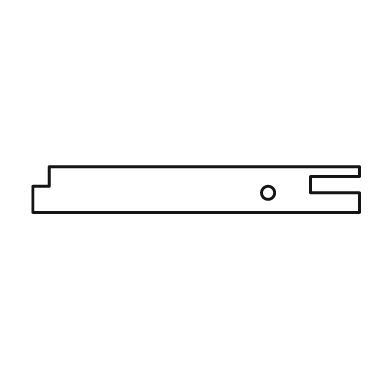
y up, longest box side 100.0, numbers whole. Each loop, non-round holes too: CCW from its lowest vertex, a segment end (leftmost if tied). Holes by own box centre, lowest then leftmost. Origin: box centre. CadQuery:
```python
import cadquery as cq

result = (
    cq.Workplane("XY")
    .moveTo(-50.0, -7.0)
    .lineTo(50.0, -7.0)
    .lineTo(50.0, -1.0)
    .lineTo(35.0, -1.0)
    .lineTo(35.0, 4.0)
    .lineTo(50.0, 4.0)
    .lineTo(50.0, 7.0)
    .lineTo(-45.0, 7.0)
    .lineTo(-45.0, 1.0)
    .lineTo(-50.0, 1.0)
    .close()
    .moveTo(22.0, -1.0)
    .circle(2.0)
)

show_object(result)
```